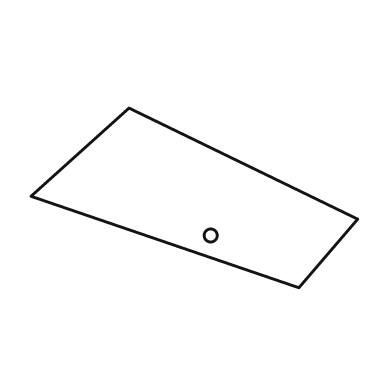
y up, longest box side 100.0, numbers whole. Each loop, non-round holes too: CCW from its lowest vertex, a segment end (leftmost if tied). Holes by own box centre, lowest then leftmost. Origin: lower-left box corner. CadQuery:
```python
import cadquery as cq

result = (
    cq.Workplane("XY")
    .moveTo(82.0, 0.0)
    .lineTo(100.0, 21.0)
    .lineTo(30.0, 55.0)
    .lineTo(0.0, 28.0)
    .close()
    .moveTo(55.0, 16.0)
    .circle(2.0)
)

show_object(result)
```